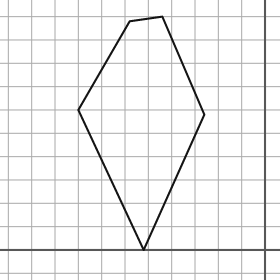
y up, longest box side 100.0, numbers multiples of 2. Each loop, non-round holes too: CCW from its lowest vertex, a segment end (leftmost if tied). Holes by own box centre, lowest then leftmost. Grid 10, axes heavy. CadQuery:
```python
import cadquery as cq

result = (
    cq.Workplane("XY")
    .moveTo(-52.0, 0.0)
    .lineTo(-26.0, 58.0)
    .lineTo(-44.0, 100.0)
    .lineTo(-58.0, 98.0)
    .lineTo(-80.0, 60.0)
    .close()
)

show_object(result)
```